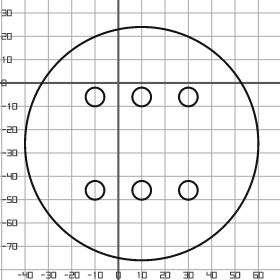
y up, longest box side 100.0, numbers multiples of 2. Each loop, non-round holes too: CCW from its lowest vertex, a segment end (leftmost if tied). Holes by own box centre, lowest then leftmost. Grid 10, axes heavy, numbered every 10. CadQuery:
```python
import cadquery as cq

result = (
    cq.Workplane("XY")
    .moveTo(10.0, -26.0)
    .circle(50.0)
    .moveTo(-10.0, -46.0)
    .circle(4.0)
    .moveTo(10.0, -46.0)
    .circle(4.0)
    .moveTo(30.0, -46.0)
    .circle(4.0)
    .moveTo(-10.0, -6.0)
    .circle(4.0)
    .moveTo(10.0, -6.0)
    .circle(4.0)
    .moveTo(30.0, -6.0)
    .circle(4.0)
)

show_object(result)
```